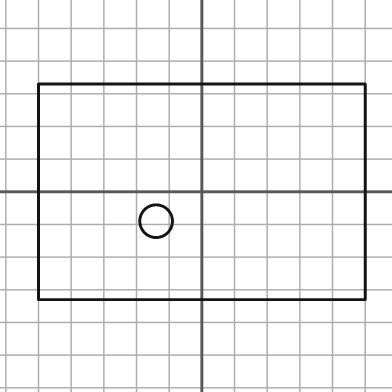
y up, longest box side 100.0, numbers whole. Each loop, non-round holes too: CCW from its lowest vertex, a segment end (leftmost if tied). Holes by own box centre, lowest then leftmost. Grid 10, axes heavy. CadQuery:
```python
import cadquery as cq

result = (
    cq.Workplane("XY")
    .moveTo(-50.0, -33.0)
    .lineTo(50.0, -33.0)
    .lineTo(50.0, 33.0)
    .lineTo(-50.0, 33.0)
    .close()
    .moveTo(-14.0, -9.0)
    .circle(5.0)
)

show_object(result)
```